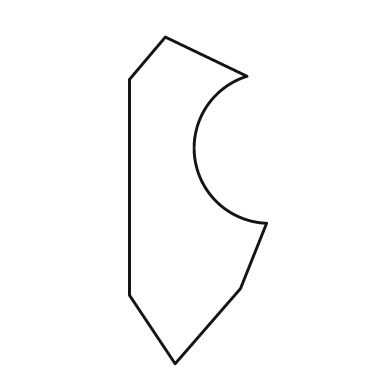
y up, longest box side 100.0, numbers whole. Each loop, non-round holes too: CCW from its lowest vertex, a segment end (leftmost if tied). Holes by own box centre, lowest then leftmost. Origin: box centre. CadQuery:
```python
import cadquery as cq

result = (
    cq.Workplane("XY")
    .moveTo(-7.0, -50.0)
    .lineTo(13.0, -27.0)
    .lineTo(21.0, -7.0)
    .threePointArc((-1.0, 13.0), (15.0, 38.0))
    .lineTo(-10.0, 50.0)
    .lineTo(-21.0, 37.0)
    .lineTo(-21.0, -29.0)
    .close()
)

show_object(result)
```